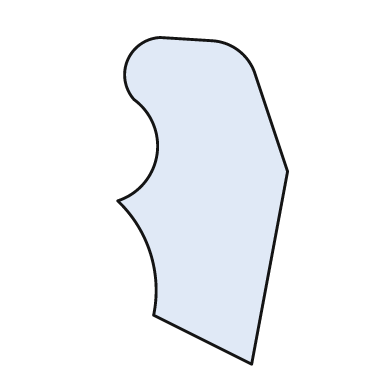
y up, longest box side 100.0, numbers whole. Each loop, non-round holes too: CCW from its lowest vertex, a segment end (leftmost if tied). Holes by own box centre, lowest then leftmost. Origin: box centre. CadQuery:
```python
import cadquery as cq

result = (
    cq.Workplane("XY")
    .moveTo(15.0, -50.0)
    .lineTo(26.0, 9.0)
    .lineTo(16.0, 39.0)
    .threePointArc((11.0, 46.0), (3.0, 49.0))
    .lineTo(-13.0, 50.0)
    .threePointArc((-23.0, 43.0), (-21.0, 31.0))
    .threePointArc((-14.0, 14.0), (-26.0, 0.0))
    .threePointArc((-16.0, -16.0), (-15.0, -35.0))
    .close()
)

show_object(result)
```